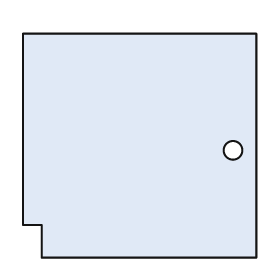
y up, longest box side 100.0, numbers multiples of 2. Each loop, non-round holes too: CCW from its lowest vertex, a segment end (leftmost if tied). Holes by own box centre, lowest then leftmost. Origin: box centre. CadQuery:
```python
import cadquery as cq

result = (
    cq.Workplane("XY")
    .moveTo(-42.0, -48.0)
    .lineTo(50.0, -48.0)
    .lineTo(50.0, 48.0)
    .lineTo(-50.0, 48.0)
    .lineTo(-50.0, -34.0)
    .lineTo(-42.0, -34.0)
    .close()
    .moveTo(40.0, -2.0)
    .circle(4.0)
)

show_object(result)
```